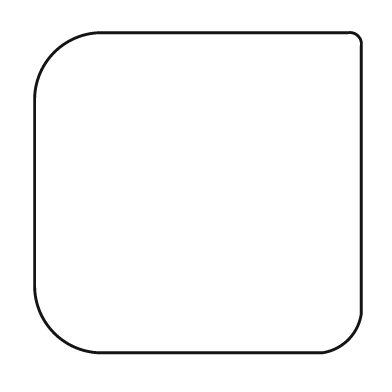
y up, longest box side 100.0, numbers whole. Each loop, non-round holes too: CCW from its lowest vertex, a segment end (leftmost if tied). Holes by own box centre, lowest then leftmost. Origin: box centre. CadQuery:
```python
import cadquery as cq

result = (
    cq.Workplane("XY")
    .moveTo(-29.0, -49.0)
    .lineTo(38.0, -49.0)
    .threePointArc((46.0, -45.0), (50.0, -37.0))
    .lineTo(50.0, 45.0)
    .threePointArc((49.0, 48.0), (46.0, 49.0))
    .lineTo(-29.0, 49.0)
    .threePointArc((-44.0, 43.0), (-50.0, 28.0))
    .lineTo(-50.0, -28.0)
    .threePointArc((-44.0, -43.0), (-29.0, -49.0))
    .close()
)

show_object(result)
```